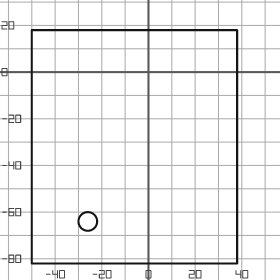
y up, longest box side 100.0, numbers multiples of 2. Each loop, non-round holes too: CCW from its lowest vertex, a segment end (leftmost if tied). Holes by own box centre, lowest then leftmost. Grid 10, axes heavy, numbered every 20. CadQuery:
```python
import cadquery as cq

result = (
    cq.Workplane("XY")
    .moveTo(-50.0, -82.0)
    .lineTo(38.0, -82.0)
    .lineTo(38.0, 18.0)
    .lineTo(-50.0, 18.0)
    .close()
    .moveTo(-26.0, -64.0)
    .circle(4.0)
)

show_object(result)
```